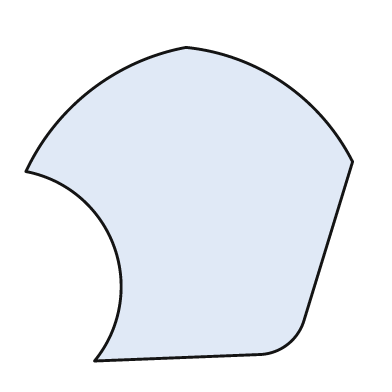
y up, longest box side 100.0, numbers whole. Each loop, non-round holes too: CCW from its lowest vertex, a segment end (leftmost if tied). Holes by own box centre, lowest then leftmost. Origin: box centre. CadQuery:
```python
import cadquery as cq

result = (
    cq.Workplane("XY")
    .moveTo(-29.0, -48.0)
    .lineTo(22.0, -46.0)
    .threePointArc((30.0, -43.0), (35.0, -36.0))
    .lineTo(50.0, 13.0)
    .threePointArc((29.0, 37.0), (-1.0, 48.0))
    .threePointArc((-30.0, 35.0), (-50.0, 10.0))
    .threePointArc((-23.0, -13.0), (-29.0, -48.0))
    .close()
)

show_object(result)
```